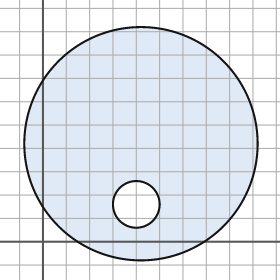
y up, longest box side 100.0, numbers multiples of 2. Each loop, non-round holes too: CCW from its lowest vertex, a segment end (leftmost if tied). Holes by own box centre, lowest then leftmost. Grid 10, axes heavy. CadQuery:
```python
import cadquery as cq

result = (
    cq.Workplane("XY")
    .moveTo(42.0, 42.0)
    .circle(50.0)
    .moveTo(40.0, 16.0)
    .circle(10.0)
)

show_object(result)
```